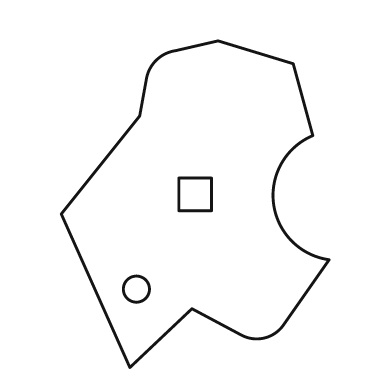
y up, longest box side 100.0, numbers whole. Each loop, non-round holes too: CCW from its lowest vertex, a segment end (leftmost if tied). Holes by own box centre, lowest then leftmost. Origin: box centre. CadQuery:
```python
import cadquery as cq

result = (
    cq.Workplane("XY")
    .moveTo(-20.0, -50.0)
    .lineTo(-1.0, -32.0)
    .lineTo(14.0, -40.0)
    .threePointArc((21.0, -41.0), (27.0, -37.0))
    .lineTo(41.0, -17.0)
    .threePointArc((24.0, 0.0), (36.0, 21.0))
    .lineTo(30.0, 43.0)
    .lineTo(7.0, 50.0)
    .lineTo(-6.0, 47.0)
    .threePointArc((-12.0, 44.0), (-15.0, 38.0))
    .lineTo(-17.0, 27.0)
    .lineTo(-41.0, -3.0)
    .close()
    .moveTo(-18.0, -26.0)
    .circle(4.0)
    .moveTo(-5.0, -2.0)
    .lineTo(5.0, -2.0)
    .lineTo(5.0, 8.0)
    .lineTo(-5.0, 8.0)
    .close()
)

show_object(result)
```